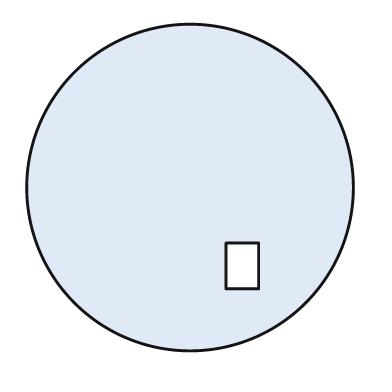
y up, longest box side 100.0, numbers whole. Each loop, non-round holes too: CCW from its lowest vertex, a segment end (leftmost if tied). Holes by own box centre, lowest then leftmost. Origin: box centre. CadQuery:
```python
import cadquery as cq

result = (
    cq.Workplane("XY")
    .moveTo(0.0, 0.0)
    .circle(50.0)
    .moveTo(11.0, -31.0)
    .lineTo(21.0, -31.0)
    .lineTo(21.0, -17.0)
    .lineTo(11.0, -17.0)
    .close()
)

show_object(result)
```